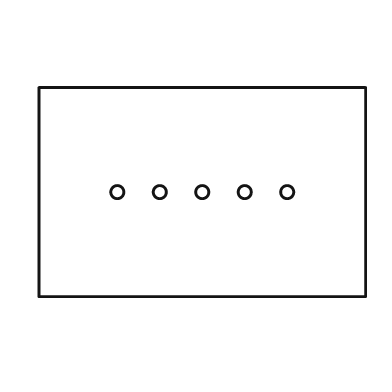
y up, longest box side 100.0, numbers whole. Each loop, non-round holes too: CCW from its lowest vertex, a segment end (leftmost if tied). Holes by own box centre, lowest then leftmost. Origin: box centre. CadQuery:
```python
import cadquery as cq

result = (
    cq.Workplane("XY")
    .moveTo(-50.0, -32.0)
    .lineTo(50.0, -32.0)
    .lineTo(50.0, 32.0)
    .lineTo(-50.0, 32.0)
    .close()
    .moveTo(-26.0, 0.0)
    .circle(2.0)
    .moveTo(-13.0, 0.0)
    .circle(2.0)
    .moveTo(0.0, 0.0)
    .circle(2.0)
    .moveTo(13.0, 0.0)
    .circle(2.0)
    .moveTo(26.0, 0.0)
    .circle(2.0)
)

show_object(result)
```